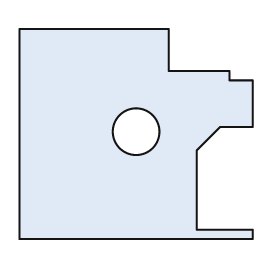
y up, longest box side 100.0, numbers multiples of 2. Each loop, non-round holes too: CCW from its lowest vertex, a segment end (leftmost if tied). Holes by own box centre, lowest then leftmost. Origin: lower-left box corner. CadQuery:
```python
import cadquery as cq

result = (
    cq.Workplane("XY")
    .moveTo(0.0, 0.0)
    .lineTo(100.0, 0.0)
    .lineTo(100.0, 4.0)
    .lineTo(76.0, 4.0)
    .lineTo(76.0, 38.0)
    .lineTo(86.0, 48.0)
    .lineTo(100.0, 48.0)
    .lineTo(100.0, 68.0)
    .lineTo(90.0, 68.0)
    .lineTo(90.0, 72.0)
    .lineTo(64.0, 72.0)
    .lineTo(64.0, 90.0)
    .lineTo(0.0, 90.0)
    .close()
    .moveTo(50.0, 46.0)
    .circle(10.0)
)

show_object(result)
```